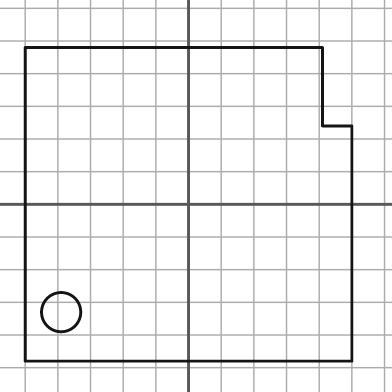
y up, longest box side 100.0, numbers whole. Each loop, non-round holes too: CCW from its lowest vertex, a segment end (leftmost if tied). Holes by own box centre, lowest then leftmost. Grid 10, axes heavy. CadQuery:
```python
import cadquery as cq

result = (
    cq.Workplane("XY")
    .moveTo(-50.0, -48.0)
    .lineTo(50.0, -48.0)
    .lineTo(50.0, 24.0)
    .lineTo(41.0, 24.0)
    .lineTo(41.0, 48.0)
    .lineTo(-50.0, 48.0)
    .close()
    .moveTo(-39.0, -33.0)
    .circle(6.0)
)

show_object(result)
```